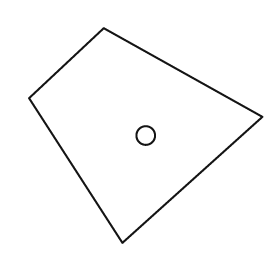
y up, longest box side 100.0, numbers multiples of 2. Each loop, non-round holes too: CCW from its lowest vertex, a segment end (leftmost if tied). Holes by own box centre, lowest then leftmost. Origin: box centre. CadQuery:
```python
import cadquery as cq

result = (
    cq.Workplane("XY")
    .moveTo(-10.0, -46.0)
    .lineTo(50.0, 8.0)
    .lineTo(-18.0, 46.0)
    .lineTo(-50.0, 16.0)
    .close()
    .moveTo(0.0, 0.0)
    .circle(4.0)
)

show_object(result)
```